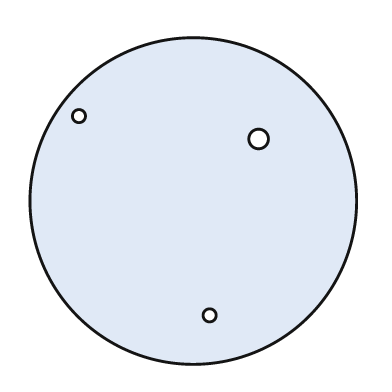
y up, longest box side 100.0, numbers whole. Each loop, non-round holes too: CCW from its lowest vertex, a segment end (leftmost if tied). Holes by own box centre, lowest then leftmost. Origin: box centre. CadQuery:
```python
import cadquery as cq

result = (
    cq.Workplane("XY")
    .moveTo(0.0, 0.0)
    .circle(50.0)
    .moveTo(5.0, -35.0)
    .circle(2.0)
    .moveTo(20.0, 19.0)
    .circle(3.0)
    .moveTo(-35.0, 26.0)
    .circle(2.0)
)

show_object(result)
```